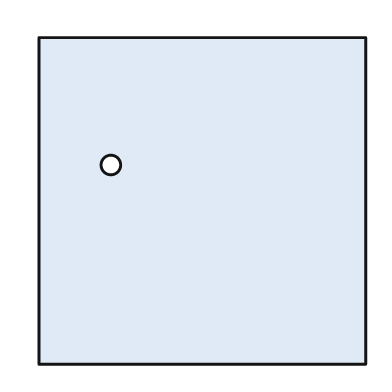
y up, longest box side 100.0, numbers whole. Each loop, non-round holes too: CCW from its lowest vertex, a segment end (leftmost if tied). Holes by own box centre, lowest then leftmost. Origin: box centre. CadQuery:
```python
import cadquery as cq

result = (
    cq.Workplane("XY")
    .moveTo(-50.0, -50.0)
    .lineTo(50.0, -50.0)
    .lineTo(50.0, 50.0)
    .lineTo(-50.0, 50.0)
    .close()
    .moveTo(-28.0, 11.0)
    .circle(3.0)
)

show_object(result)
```